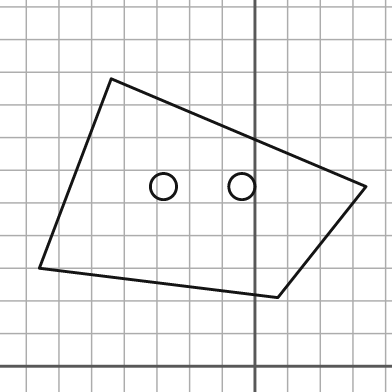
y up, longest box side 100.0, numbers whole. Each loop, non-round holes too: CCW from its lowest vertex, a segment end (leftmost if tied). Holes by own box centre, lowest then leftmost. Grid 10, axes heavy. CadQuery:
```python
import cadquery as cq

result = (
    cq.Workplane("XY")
    .moveTo(7.0, 21.0)
    .lineTo(34.0, 55.0)
    .lineTo(-44.0, 88.0)
    .lineTo(-66.0, 30.0)
    .close()
    .moveTo(-28.0, 55.0)
    .circle(4.0)
    .moveTo(-4.0, 55.0)
    .circle(4.0)
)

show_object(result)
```